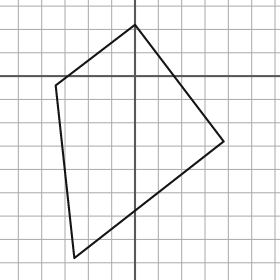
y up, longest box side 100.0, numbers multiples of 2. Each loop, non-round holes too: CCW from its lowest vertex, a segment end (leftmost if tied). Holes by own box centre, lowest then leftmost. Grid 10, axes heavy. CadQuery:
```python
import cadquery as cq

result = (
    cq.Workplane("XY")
    .moveTo(-26.0, -78.0)
    .lineTo(38.0, -28.0)
    .lineTo(0.0, 22.0)
    .lineTo(-34.0, -4.0)
    .close()
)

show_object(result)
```